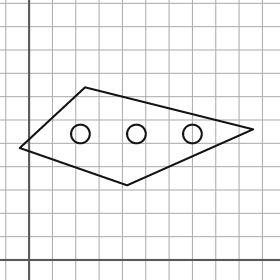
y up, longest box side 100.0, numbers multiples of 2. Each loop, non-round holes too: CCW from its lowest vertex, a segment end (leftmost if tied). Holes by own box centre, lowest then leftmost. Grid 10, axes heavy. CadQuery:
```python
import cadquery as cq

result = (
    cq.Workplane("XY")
    .moveTo(42.0, 32.0)
    .lineTo(96.0, 56.0)
    .lineTo(24.0, 74.0)
    .lineTo(-4.0, 48.0)
    .close()
    .moveTo(22.0, 54.0)
    .circle(4.0)
    .moveTo(46.0, 54.0)
    .circle(4.0)
    .moveTo(70.0, 54.0)
    .circle(4.0)
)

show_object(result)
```